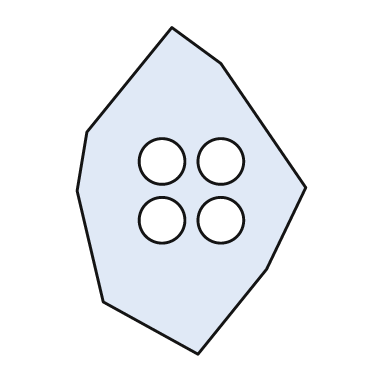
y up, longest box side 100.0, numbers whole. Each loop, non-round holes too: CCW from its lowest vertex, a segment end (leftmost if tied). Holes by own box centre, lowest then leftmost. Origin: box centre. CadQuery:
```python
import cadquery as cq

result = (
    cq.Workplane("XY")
    .moveTo(2.0, -50.0)
    .lineTo(23.0, -24.0)
    .lineTo(35.0, 1.0)
    .lineTo(9.0, 39.0)
    .lineTo(-6.0, 50.0)
    .lineTo(-32.0, 18.0)
    .lineTo(-35.0, 0.0)
    .lineTo(-27.0, -34.0)
    .close()
    .moveTo(-9.0, -9.0)
    .circle(7.0)
    .moveTo(9.0, -9.0)
    .circle(7.0)
    .moveTo(-9.0, 9.0)
    .circle(7.0)
    .moveTo(9.0, 9.0)
    .circle(7.0)
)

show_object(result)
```